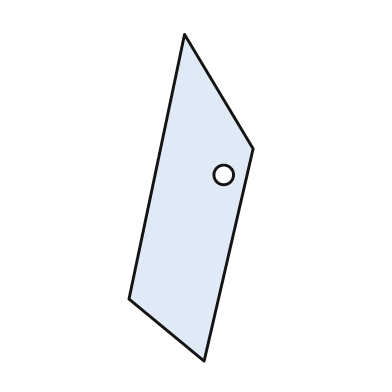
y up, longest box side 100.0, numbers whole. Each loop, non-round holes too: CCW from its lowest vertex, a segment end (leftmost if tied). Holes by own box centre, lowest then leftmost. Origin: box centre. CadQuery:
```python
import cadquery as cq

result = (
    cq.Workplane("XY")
    .moveTo(4.0, -50.0)
    .lineTo(19.0, 15.0)
    .lineTo(-2.0, 50.0)
    .lineTo(-19.0, -31.0)
    .close()
    .moveTo(10.0, 7.0)
    .circle(3.0)
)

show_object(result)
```